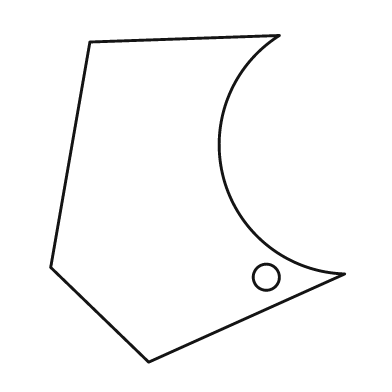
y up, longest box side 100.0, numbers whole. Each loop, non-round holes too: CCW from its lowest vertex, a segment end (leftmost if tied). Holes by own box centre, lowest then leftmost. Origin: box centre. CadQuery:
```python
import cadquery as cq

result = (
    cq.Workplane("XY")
    .moveTo(-15.0, -50.0)
    .lineTo(45.0, -23.0)
    .threePointArc((8.0, 6.0), (25.0, 50.0))
    .lineTo(-33.0, 48.0)
    .lineTo(-45.0, -21.0)
    .close()
    .moveTo(21.0, -24.0)
    .circle(4.0)
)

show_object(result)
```